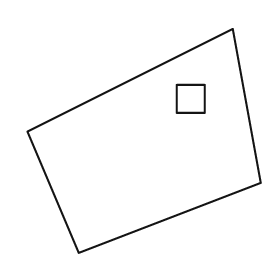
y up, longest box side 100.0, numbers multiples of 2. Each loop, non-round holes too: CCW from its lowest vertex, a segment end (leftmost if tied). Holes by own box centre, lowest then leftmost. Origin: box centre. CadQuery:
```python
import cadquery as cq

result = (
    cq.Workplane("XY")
    .moveTo(-28.0, -48.0)
    .lineTo(50.0, -18.0)
    .lineTo(38.0, 48.0)
    .lineTo(-50.0, 4.0)
    .close()
    .moveTo(14.0, 12.0)
    .lineTo(26.0, 12.0)
    .lineTo(26.0, 24.0)
    .lineTo(14.0, 24.0)
    .close()
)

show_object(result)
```